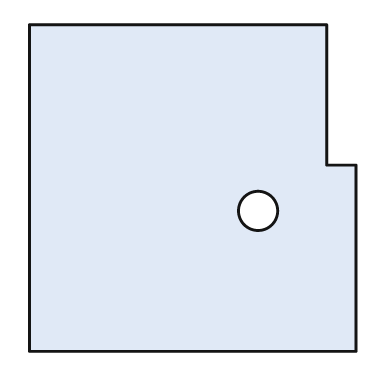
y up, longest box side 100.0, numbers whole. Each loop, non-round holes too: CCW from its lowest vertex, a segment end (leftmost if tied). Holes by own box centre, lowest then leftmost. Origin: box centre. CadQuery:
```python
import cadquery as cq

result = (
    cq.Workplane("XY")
    .moveTo(-50.0, -50.0)
    .lineTo(50.0, -50.0)
    .lineTo(50.0, 7.0)
    .lineTo(41.0, 7.0)
    .lineTo(41.0, 50.0)
    .lineTo(-50.0, 50.0)
    .close()
    .moveTo(20.0, -7.0)
    .circle(6.0)
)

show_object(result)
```